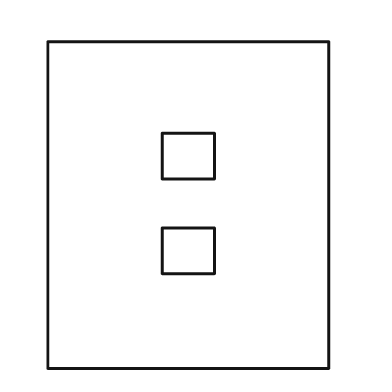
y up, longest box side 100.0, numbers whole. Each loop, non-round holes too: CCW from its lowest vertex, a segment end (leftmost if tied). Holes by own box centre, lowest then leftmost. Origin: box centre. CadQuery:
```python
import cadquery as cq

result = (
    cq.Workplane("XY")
    .moveTo(-43.0, -50.0)
    .lineTo(43.0, -50.0)
    .lineTo(43.0, 50.0)
    .lineTo(-43.0, 50.0)
    .close()
    .moveTo(-8.0, -21.0)
    .lineTo(8.0, -21.0)
    .lineTo(8.0, -7.0)
    .lineTo(-8.0, -7.0)
    .close()
    .moveTo(-8.0, 8.0)
    .lineTo(8.0, 8.0)
    .lineTo(8.0, 22.0)
    .lineTo(-8.0, 22.0)
    .close()
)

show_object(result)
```